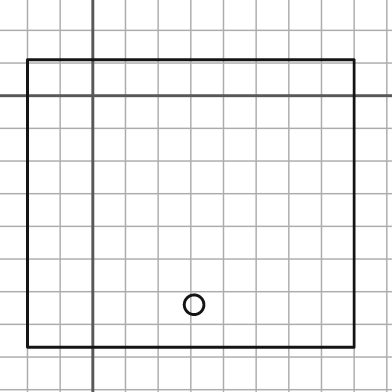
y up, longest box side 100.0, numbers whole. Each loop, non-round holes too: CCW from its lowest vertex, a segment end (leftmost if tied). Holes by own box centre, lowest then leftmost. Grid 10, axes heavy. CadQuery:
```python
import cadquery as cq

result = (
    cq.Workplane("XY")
    .moveTo(-20.0, -77.0)
    .lineTo(80.0, -77.0)
    .lineTo(80.0, 11.0)
    .lineTo(-20.0, 11.0)
    .close()
    .moveTo(31.0, -64.0)
    .circle(3.0)
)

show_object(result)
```